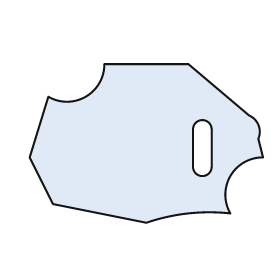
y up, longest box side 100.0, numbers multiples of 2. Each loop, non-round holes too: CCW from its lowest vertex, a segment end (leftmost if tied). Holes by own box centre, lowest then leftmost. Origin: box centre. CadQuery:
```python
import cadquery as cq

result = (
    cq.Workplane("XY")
    .moveTo(0.0, -34.0)
    .threePointArc((18.0, -30.0), (36.0, -30.0))
    .threePointArc((36.0, -14.0), (50.0, -6.0))
    .lineTo(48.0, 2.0)
    .threePointArc((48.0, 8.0), (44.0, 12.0))
    .lineTo(18.0, 34.0)
    .lineTo(-18.0, 34.0)
    .threePointArc((-26.0, 20.0), (-42.0, 20.0))
    .lineTo(-50.0, -6.0)
    .lineTo(-40.0, -26.0)
    .close()
    .moveTo(20.0, -10.0)
    .threePointArc((24.0, -14.0), (28.0, -10.0))
    .lineTo(28.0, 6.0)
    .threePointArc((24.0, 10.0), (20.0, 6.0))
    .close()
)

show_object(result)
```